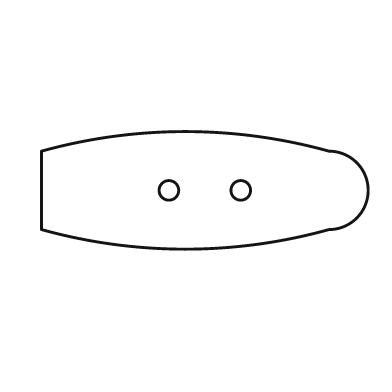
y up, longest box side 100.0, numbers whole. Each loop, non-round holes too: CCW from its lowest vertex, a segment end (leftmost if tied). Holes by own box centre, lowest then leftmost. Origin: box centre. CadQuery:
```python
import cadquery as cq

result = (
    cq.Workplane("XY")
    .moveTo(-50.0, -12.0)
    .threePointArc((-6.0, -18.0), (38.0, -12.0))
    .threePointArc((50.0, 0.0), (38.0, 12.0))
    .threePointArc((-6.0, 18.0), (-50.0, 12.0))
    .close()
    .moveTo(-11.0, 0.0)
    .circle(3.0)
    .moveTo(11.0, 0.0)
    .circle(3.0)
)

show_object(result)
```